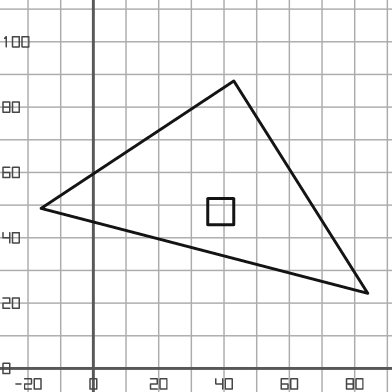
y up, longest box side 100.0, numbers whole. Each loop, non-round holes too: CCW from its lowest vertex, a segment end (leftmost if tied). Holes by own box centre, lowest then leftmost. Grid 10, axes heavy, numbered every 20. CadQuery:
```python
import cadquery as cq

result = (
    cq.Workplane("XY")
    .moveTo(84.0, 23.0)
    .lineTo(43.0, 88.0)
    .lineTo(-16.0, 49.0)
    .close()
    .moveTo(35.0, 44.0)
    .lineTo(43.0, 44.0)
    .lineTo(43.0, 52.0)
    .lineTo(35.0, 52.0)
    .close()
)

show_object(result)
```